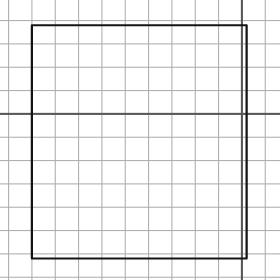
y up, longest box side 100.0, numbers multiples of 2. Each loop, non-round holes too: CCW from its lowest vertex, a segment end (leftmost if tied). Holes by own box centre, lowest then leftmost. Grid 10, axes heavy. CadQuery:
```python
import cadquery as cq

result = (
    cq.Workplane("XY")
    .moveTo(-90.0, -62.0)
    .lineTo(2.0, -62.0)
    .lineTo(2.0, 38.0)
    .lineTo(-90.0, 38.0)
    .close()
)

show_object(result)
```